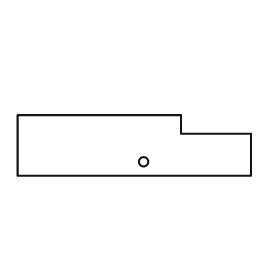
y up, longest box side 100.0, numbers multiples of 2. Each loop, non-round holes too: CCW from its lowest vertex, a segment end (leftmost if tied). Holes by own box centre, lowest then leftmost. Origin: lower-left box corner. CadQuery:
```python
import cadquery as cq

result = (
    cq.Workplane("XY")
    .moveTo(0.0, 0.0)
    .lineTo(100.0, 0.0)
    .lineTo(100.0, 18.0)
    .lineTo(70.0, 18.0)
    .lineTo(70.0, 26.0)
    .lineTo(0.0, 26.0)
    .close()
    .moveTo(54.0, 6.0)
    .circle(2.0)
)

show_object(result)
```